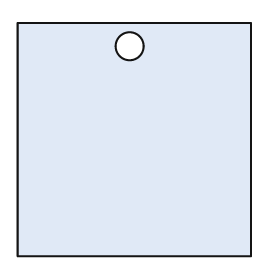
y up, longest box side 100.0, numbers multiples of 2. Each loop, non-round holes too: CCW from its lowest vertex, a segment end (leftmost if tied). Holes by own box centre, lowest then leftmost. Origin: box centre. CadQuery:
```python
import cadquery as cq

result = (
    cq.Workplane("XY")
    .moveTo(-50.0, -50.0)
    .lineTo(50.0, -50.0)
    .lineTo(50.0, 50.0)
    .lineTo(-50.0, 50.0)
    .close()
    .moveTo(-2.0, 40.0)
    .circle(6.0)
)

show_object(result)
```